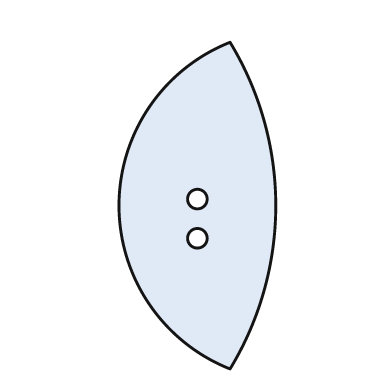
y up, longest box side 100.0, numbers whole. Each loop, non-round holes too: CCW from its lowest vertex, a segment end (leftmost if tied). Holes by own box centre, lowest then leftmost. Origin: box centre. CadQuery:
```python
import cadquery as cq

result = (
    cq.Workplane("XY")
    .moveTo(10.0, -50.0)
    .threePointArc((24.0, 0.0), (10.0, 50.0))
    .threePointArc((-24.0, 0.0), (10.0, -50.0))
    .close()
    .moveTo(0.0, -10.0)
    .circle(3.0)
    .moveTo(0.0, 2.0)
    .circle(3.0)
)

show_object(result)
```